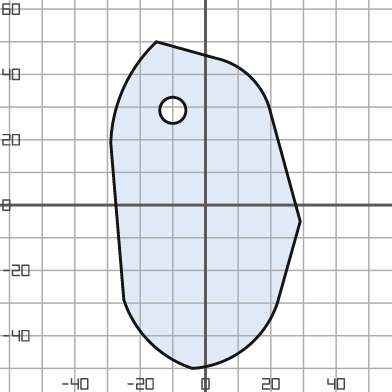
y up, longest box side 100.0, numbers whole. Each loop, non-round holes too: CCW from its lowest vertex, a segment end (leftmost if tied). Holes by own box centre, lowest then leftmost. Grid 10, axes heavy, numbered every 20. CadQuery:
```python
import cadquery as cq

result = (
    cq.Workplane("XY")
    .moveTo(-4.0, -50.0)
    .threePointArc((12.0, -44.0), (22.0, -30.0))
    .lineTo(29.0, -5.0)
    .lineTo(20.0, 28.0)
    .threePointArc((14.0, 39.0), (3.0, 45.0))
    .lineTo(-15.0, 50.0)
    .threePointArc((-25.0, 36.0), (-29.0, 19.0))
    .lineTo(-25.0, -29.0)
    .threePointArc((-17.0, -42.0), (-4.0, -50.0))
    .close()
    .moveTo(-10.0, 29.0)
    .circle(4.0)
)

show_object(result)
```